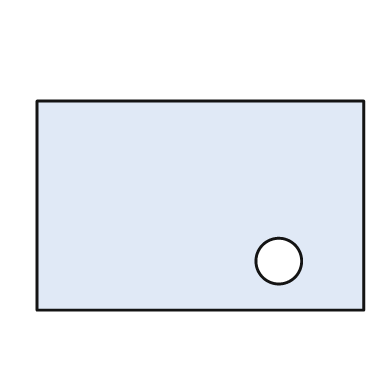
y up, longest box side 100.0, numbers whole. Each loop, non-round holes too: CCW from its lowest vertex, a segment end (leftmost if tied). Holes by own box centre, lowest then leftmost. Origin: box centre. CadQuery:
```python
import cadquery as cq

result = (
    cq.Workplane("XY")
    .moveTo(-50.0, -32.0)
    .lineTo(50.0, -32.0)
    .lineTo(50.0, 32.0)
    .lineTo(-50.0, 32.0)
    .close()
    .moveTo(24.0, -17.0)
    .circle(7.0)
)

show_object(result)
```